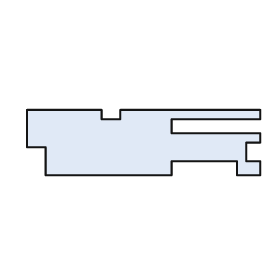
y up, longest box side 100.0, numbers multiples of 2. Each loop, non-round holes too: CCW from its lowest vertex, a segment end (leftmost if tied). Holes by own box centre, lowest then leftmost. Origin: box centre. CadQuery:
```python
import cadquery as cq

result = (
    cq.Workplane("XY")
    .moveTo(-42.0, -14.0)
    .lineTo(12.0, -14.0)
    .lineTo(12.0, -8.0)
    .lineTo(40.0, -8.0)
    .lineTo(40.0, -14.0)
    .lineTo(50.0, -14.0)
    .lineTo(50.0, -8.0)
    .lineTo(44.0, -8.0)
    .lineTo(44.0, 0.0)
    .lineTo(50.0, 0.0)
    .lineTo(50.0, 4.0)
    .lineTo(12.0, 4.0)
    .lineTo(12.0, 10.0)
    .lineTo(50.0, 10.0)
    .lineTo(50.0, 14.0)
    .lineTo(-10.0, 14.0)
    .lineTo(-10.0, 10.0)
    .lineTo(-18.0, 10.0)
    .lineTo(-18.0, 14.0)
    .lineTo(-50.0, 14.0)
    .lineTo(-50.0, -2.0)
    .lineTo(-42.0, -2.0)
    .close()
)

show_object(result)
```